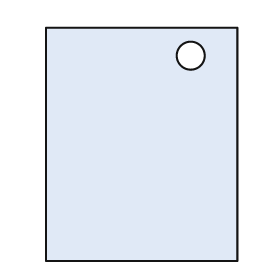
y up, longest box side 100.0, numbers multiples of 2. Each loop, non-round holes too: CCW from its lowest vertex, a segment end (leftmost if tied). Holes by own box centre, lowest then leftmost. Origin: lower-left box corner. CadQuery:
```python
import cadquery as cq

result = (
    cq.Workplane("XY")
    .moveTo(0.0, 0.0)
    .lineTo(82.0, 0.0)
    .lineTo(82.0, 100.0)
    .lineTo(0.0, 100.0)
    .close()
    .moveTo(62.0, 88.0)
    .circle(6.0)
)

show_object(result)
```